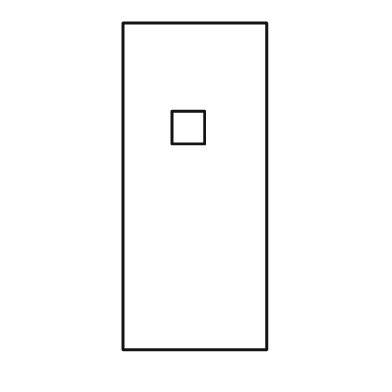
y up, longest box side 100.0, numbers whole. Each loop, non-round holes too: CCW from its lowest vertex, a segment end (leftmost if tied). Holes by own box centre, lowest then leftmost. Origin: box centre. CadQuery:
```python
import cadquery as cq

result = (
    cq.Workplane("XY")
    .moveTo(-22.0, -50.0)
    .lineTo(22.0, -50.0)
    .lineTo(22.0, 50.0)
    .lineTo(-22.0, 50.0)
    .close()
    .moveTo(-7.0, 13.0)
    .lineTo(3.0, 13.0)
    .lineTo(3.0, 23.0)
    .lineTo(-7.0, 23.0)
    .close()
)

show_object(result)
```